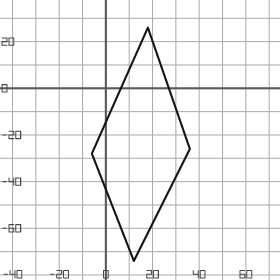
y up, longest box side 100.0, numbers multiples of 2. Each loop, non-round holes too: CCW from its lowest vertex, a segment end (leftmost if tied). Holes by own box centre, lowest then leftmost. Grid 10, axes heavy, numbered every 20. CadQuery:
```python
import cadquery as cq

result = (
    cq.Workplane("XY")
    .moveTo(12.0, -74.0)
    .lineTo(36.0, -26.0)
    .lineTo(18.0, 26.0)
    .lineTo(-6.0, -28.0)
    .close()
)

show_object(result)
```